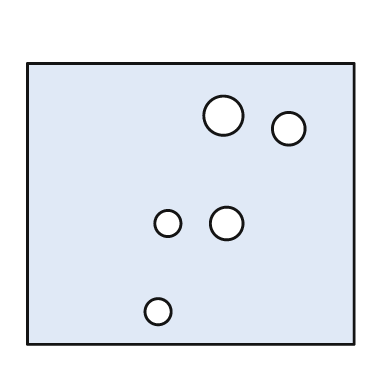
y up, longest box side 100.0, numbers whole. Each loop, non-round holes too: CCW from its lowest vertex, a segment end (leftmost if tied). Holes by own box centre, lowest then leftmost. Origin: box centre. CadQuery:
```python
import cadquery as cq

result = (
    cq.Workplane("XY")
    .moveTo(-50.0, -43.0)
    .lineTo(50.0, -43.0)
    .lineTo(50.0, 43.0)
    .lineTo(-50.0, 43.0)
    .close()
    .moveTo(-10.0, -33.0)
    .circle(4.0)
    .moveTo(-7.0, -6.0)
    .circle(4.0)
    .moveTo(11.0, -6.0)
    .circle(5.0)
    .moveTo(30.0, 23.0)
    .circle(5.0)
    .moveTo(10.0, 27.0)
    .circle(6.0)
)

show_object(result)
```